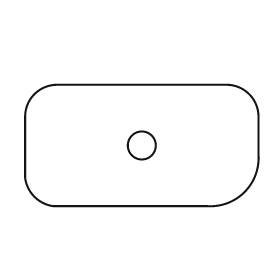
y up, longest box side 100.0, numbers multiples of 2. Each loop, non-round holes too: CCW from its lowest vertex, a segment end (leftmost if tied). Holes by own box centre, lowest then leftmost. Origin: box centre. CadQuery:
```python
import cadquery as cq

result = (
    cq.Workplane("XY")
    .moveTo(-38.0, -26.0)
    .lineTo(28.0, -26.0)
    .threePointArc((44.0, -20.0), (50.0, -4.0))
    .lineTo(50.0, 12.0)
    .threePointArc((46.0, 22.0), (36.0, 26.0))
    .lineTo(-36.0, 26.0)
    .threePointArc((-46.0, 22.0), (-50.0, 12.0))
    .lineTo(-50.0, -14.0)
    .threePointArc((-46.0, -22.0), (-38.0, -26.0))
    .close()
    .moveTo(0.0, 0.0)
    .circle(6.0)
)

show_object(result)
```